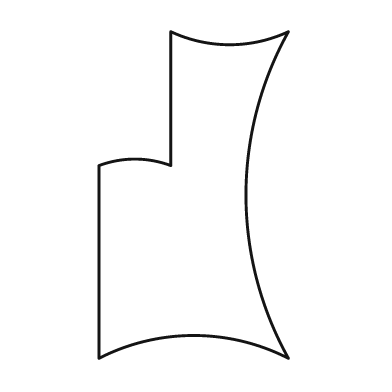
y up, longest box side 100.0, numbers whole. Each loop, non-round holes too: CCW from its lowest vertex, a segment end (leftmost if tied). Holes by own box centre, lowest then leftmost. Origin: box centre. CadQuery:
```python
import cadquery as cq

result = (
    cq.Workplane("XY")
    .moveTo(-29.0, -50.0)
    .threePointArc((0.0, -43.0), (29.0, -50.0))
    .threePointArc((16.0, 0.0), (29.0, 50.0))
    .threePointArc((11.0, 46.0), (-7.0, 50.0))
    .lineTo(-7.0, 9.0)
    .threePointArc((-18.0, 11.0), (-29.0, 9.0))
    .close()
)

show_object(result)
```